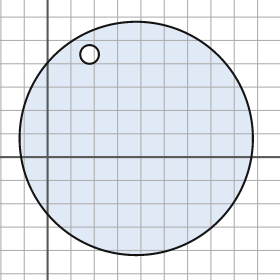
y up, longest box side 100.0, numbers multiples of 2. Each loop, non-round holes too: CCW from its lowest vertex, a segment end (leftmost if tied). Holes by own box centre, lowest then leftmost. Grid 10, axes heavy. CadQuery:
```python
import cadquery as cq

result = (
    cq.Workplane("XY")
    .moveTo(38.0, 8.0)
    .circle(50.0)
    .moveTo(18.0, 44.0)
    .circle(4.0)
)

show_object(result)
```